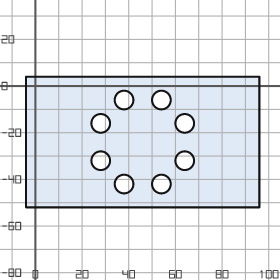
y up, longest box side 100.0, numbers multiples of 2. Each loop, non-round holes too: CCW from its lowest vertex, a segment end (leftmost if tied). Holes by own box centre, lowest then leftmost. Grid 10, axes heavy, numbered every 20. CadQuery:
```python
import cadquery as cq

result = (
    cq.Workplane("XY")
    .moveTo(-4.0, -52.0)
    .lineTo(96.0, -52.0)
    .lineTo(96.0, 4.0)
    .lineTo(-4.0, 4.0)
    .close()
    .moveTo(38.0, -42.0)
    .circle(4.0)
    .moveTo(54.0, -42.0)
    .circle(4.0)
    .moveTo(28.0, -32.0)
    .circle(4.0)
    .moveTo(64.0, -32.0)
    .circle(4.0)
    .moveTo(28.0, -16.0)
    .circle(4.0)
    .moveTo(64.0, -16.0)
    .circle(4.0)
    .moveTo(38.0, -6.0)
    .circle(4.0)
    .moveTo(54.0, -6.0)
    .circle(4.0)
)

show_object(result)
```